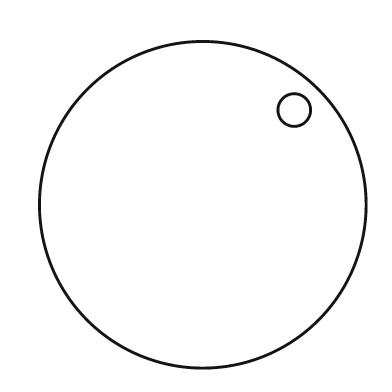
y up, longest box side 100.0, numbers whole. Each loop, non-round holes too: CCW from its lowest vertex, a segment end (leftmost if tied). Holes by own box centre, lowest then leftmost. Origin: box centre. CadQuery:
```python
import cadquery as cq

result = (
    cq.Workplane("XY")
    .moveTo(0.0, 0.0)
    .circle(50.0)
    .moveTo(28.0, 29.0)
    .circle(5.0)
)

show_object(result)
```